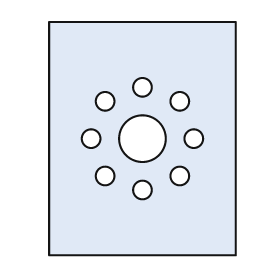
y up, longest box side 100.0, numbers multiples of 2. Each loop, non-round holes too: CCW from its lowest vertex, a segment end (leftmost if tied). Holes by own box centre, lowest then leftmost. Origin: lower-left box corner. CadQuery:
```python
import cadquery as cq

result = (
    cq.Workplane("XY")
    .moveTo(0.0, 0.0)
    .lineTo(80.0, 0.0)
    .lineTo(80.0, 100.0)
    .lineTo(0.0, 100.0)
    .close()
    .moveTo(40.0, 28.0)
    .circle(4.0)
    .moveTo(24.0, 34.0)
    .circle(4.0)
    .moveTo(56.0, 34.0)
    .circle(4.0)
    .moveTo(18.0, 50.0)
    .circle(4.0)
    .moveTo(40.0, 50.0)
    .circle(10.0)
    .moveTo(62.0, 50.0)
    .circle(4.0)
    .moveTo(24.0, 66.0)
    .circle(4.0)
    .moveTo(56.0, 66.0)
    .circle(4.0)
    .moveTo(40.0, 72.0)
    .circle(4.0)
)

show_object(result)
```